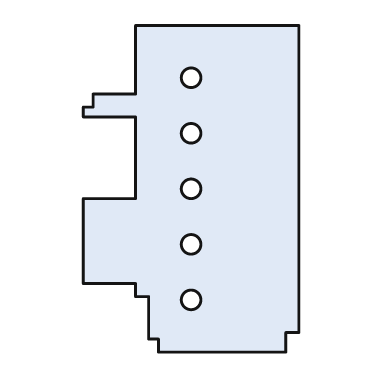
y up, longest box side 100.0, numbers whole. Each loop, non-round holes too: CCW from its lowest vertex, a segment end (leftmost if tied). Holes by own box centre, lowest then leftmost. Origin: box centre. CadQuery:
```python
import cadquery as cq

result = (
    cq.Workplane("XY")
    .moveTo(-10.0, -50.0)
    .lineTo(29.0, -50.0)
    .lineTo(29.0, -44.0)
    .lineTo(33.0, -44.0)
    .lineTo(33.0, 50.0)
    .lineTo(-17.0, 50.0)
    .lineTo(-17.0, 29.0)
    .lineTo(-30.0, 29.0)
    .lineTo(-30.0, 25.0)
    .lineTo(-33.0, 25.0)
    .lineTo(-33.0, 22.0)
    .lineTo(-17.0, 22.0)
    .lineTo(-17.0, -3.0)
    .lineTo(-33.0, -3.0)
    .lineTo(-33.0, -29.0)
    .lineTo(-17.0, -29.0)
    .lineTo(-17.0, -33.0)
    .lineTo(-13.0, -33.0)
    .lineTo(-13.0, -46.0)
    .lineTo(-10.0, -46.0)
    .close()
    .moveTo(0.0, -34.0)
    .circle(3.0)
    .moveTo(0.0, -17.0)
    .circle(3.0)
    .moveTo(0.0, 0.0)
    .circle(3.0)
    .moveTo(0.0, 17.0)
    .circle(3.0)
    .moveTo(0.0, 34.0)
    .circle(3.0)
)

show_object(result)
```